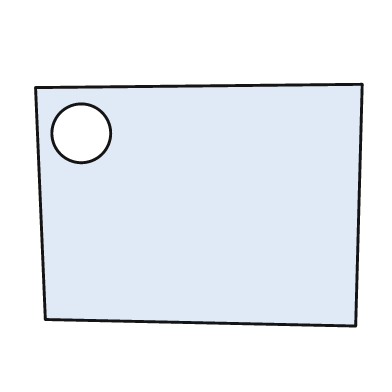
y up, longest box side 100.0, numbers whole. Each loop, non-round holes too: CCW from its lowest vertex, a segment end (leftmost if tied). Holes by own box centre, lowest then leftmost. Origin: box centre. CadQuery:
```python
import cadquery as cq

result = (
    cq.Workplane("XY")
    .moveTo(48.0, -37.0)
    .lineTo(50.0, 37.0)
    .lineTo(-50.0, 36.0)
    .lineTo(-47.0, -35.0)
    .close()
    .moveTo(-36.0, 22.0)
    .circle(9.0)
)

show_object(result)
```